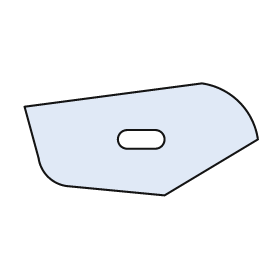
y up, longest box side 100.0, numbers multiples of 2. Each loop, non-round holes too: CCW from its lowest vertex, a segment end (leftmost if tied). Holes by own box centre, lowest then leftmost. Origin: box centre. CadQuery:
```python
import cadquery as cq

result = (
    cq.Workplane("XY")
    .moveTo(10.0, -24.0)
    .lineTo(50.0, 0.0)
    .threePointArc((42.0, 16.0), (26.0, 24.0))
    .lineTo(-50.0, 14.0)
    .lineTo(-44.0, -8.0)
    .threePointArc((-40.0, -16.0), (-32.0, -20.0))
    .close()
    .moveTo(-6.0, -4.0)
    .lineTo(6.0, -4.0)
    .threePointArc((10.0, 0.0), (6.0, 4.0))
    .lineTo(-6.0, 4.0)
    .threePointArc((-10.0, 0.0), (-6.0, -4.0))
    .close()
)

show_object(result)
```